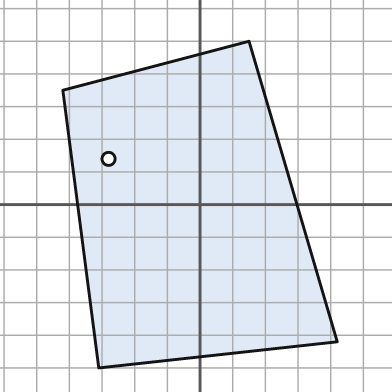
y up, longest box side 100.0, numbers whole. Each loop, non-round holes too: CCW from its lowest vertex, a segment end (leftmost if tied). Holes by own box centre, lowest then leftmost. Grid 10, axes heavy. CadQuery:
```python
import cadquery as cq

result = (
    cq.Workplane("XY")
    .moveTo(-31.0, -50.0)
    .lineTo(42.0, -42.0)
    .lineTo(15.0, 50.0)
    .lineTo(-42.0, 35.0)
    .close()
    .moveTo(-28.0, 14.0)
    .circle(2.0)
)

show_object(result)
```